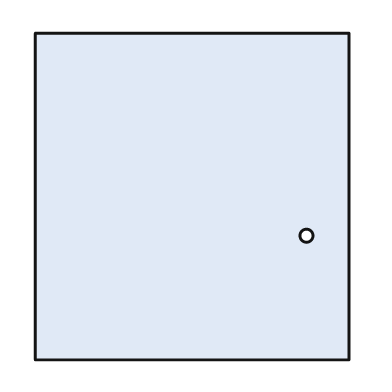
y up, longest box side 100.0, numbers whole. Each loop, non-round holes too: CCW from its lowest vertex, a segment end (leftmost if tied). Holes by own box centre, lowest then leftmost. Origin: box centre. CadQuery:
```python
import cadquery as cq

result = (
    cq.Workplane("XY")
    .moveTo(-48.0, -50.0)
    .lineTo(48.0, -50.0)
    .lineTo(48.0, 50.0)
    .lineTo(-48.0, 50.0)
    .close()
    .moveTo(35.0, -12.0)
    .circle(2.0)
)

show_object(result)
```